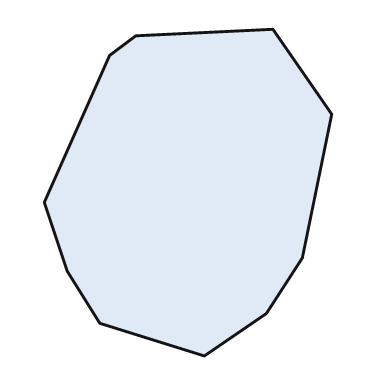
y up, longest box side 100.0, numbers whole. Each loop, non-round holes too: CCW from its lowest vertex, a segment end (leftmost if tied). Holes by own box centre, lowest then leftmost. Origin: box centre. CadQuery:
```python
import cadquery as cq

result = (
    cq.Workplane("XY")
    .moveTo(5.0, -50.0)
    .lineTo(24.0, -37.0)
    .lineTo(35.0, -20.0)
    .lineTo(44.0, 24.0)
    .lineTo(26.0, 50.0)
    .lineTo(-16.0, 48.0)
    .lineTo(-24.0, 42.0)
    .lineTo(-44.0, -3.0)
    .lineTo(-37.0, -24.0)
    .lineTo(-27.0, -40.0)
    .close()
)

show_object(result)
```